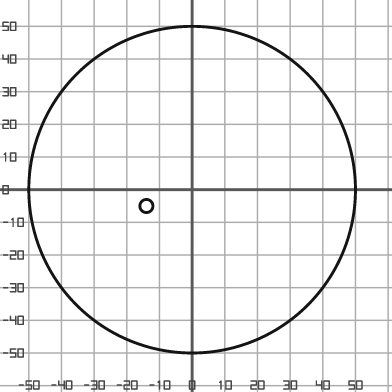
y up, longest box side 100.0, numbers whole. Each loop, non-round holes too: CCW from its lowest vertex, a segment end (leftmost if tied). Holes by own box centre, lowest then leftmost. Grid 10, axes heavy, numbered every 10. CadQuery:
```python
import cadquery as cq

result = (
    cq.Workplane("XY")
    .moveTo(0.0, 0.0)
    .circle(50.0)
    .moveTo(-14.0, -5.0)
    .circle(2.0)
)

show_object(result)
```